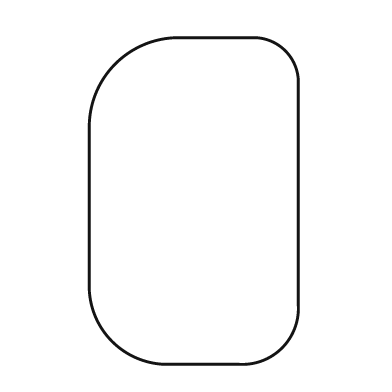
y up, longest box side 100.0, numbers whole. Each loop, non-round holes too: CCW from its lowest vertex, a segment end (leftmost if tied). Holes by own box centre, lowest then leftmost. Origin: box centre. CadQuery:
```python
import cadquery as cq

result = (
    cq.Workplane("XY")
    .moveTo(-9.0, -50.0)
    .lineTo(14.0, -50.0)
    .threePointArc((27.0, -45.0), (32.0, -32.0))
    .lineTo(32.0, 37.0)
    .threePointArc((28.0, 46.0), (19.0, 50.0))
    .lineTo(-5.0, 50.0)
    .threePointArc((-24.0, 42.0), (-32.0, 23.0))
    .lineTo(-32.0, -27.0)
    .threePointArc((-25.0, -43.0), (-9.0, -50.0))
    .close()
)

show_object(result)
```